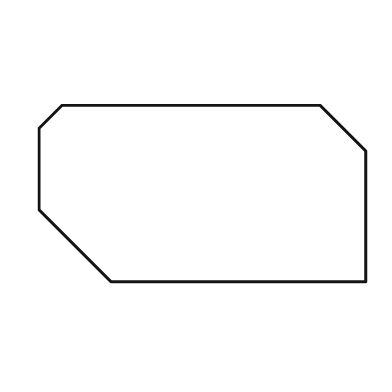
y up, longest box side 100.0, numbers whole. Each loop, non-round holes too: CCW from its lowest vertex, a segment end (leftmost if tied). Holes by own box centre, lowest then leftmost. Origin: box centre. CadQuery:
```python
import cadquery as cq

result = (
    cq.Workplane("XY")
    .moveTo(-28.0, -27.0)
    .lineTo(50.0, -27.0)
    .lineTo(50.0, 13.0)
    .lineTo(36.0, 27.0)
    .lineTo(-43.0, 27.0)
    .lineTo(-50.0, 20.0)
    .lineTo(-50.0, -5.0)
    .close()
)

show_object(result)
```